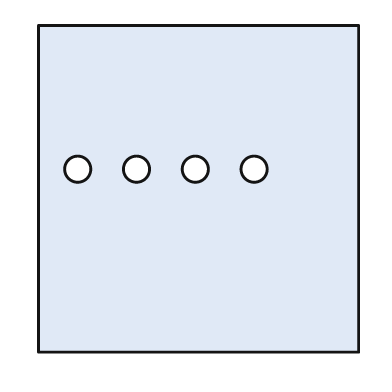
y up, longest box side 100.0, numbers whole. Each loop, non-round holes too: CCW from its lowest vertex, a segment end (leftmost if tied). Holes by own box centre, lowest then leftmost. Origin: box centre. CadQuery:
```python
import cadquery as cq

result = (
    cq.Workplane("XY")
    .moveTo(-49.0, -50.0)
    .lineTo(49.0, -50.0)
    .lineTo(49.0, 50.0)
    .lineTo(-49.0, 50.0)
    .close()
    .moveTo(-37.0, 6.0)
    .circle(4.0)
    .moveTo(-19.0, 6.0)
    .circle(4.0)
    .moveTo(-1.0, 6.0)
    .circle(4.0)
    .moveTo(17.0, 6.0)
    .circle(4.0)
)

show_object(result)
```